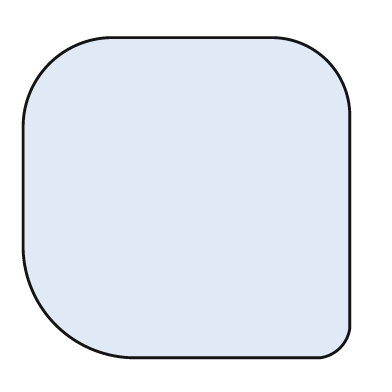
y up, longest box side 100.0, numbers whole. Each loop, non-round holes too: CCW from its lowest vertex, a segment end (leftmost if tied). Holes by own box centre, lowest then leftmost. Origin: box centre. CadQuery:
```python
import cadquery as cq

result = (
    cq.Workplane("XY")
    .moveTo(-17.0, -49.0)
    .lineTo(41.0, -49.0)
    .threePointArc((47.0, -46.0), (50.0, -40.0))
    .lineTo(50.0, 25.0)
    .threePointArc((43.0, 42.0), (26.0, 49.0))
    .lineTo(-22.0, 49.0)
    .threePointArc((-42.0, 41.0), (-50.0, 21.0))
    .lineTo(-50.0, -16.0)
    .threePointArc((-40.0, -39.0), (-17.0, -49.0))
    .close()
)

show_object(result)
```